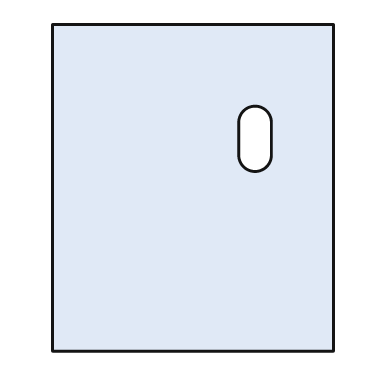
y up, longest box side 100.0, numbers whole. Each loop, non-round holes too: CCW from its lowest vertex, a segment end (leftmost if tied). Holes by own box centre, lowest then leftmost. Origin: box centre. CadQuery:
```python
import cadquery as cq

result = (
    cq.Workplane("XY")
    .moveTo(-43.0, -50.0)
    .lineTo(43.0, -50.0)
    .lineTo(43.0, 50.0)
    .lineTo(-43.0, 50.0)
    .close()
    .moveTo(14.0, 10.0)
    .threePointArc((19.0, 5.0), (24.0, 10.0))
    .lineTo(24.0, 20.0)
    .threePointArc((19.0, 25.0), (14.0, 20.0))
    .close()
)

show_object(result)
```